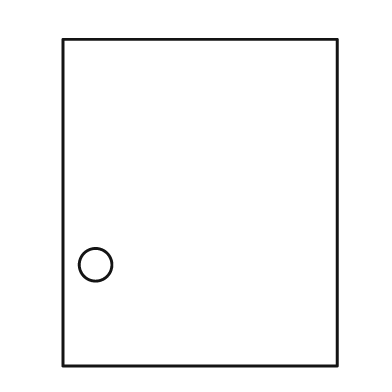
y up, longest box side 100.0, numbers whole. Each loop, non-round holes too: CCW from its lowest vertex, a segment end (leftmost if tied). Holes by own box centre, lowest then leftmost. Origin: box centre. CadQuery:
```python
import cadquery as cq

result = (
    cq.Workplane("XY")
    .moveTo(-42.0, -50.0)
    .lineTo(42.0, -50.0)
    .lineTo(42.0, 50.0)
    .lineTo(-42.0, 50.0)
    .close()
    .moveTo(-32.0, -19.0)
    .circle(5.0)
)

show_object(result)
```